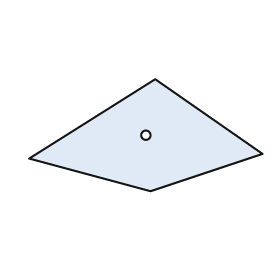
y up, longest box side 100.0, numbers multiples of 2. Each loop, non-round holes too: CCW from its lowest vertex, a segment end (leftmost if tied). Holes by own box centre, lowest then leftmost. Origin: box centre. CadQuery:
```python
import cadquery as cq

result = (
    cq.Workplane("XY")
    .moveTo(2.0, -24.0)
    .lineTo(50.0, -8.0)
    .lineTo(4.0, 24.0)
    .lineTo(-50.0, -10.0)
    .close()
    .moveTo(0.0, 0.0)
    .circle(2.0)
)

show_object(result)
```